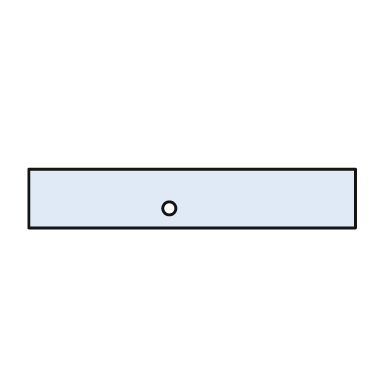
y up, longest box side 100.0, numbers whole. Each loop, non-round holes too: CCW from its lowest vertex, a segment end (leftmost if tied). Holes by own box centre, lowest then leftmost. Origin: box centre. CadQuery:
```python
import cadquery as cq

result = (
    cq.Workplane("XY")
    .moveTo(-50.0, -9.0)
    .lineTo(50.0, -9.0)
    .lineTo(50.0, 9.0)
    .lineTo(-50.0, 9.0)
    .close()
    .moveTo(-7.0, -3.0)
    .circle(2.0)
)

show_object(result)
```